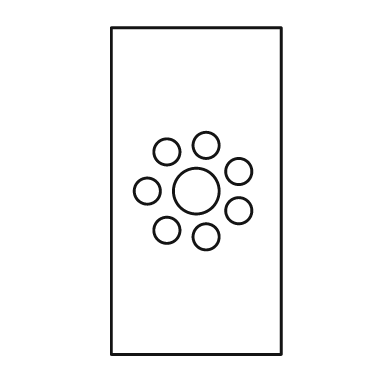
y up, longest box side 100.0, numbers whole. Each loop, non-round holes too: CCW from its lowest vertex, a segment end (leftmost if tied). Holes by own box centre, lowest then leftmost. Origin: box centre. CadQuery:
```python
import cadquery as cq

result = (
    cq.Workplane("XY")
    .moveTo(-26.0, -50.0)
    .lineTo(26.0, -50.0)
    .lineTo(26.0, 50.0)
    .lineTo(-26.0, 50.0)
    .close()
    .moveTo(3.0, -14.0)
    .circle(4.0)
    .moveTo(-9.0, -12.0)
    .circle(4.0)
    .moveTo(13.0, -6.0)
    .circle(4.0)
    .moveTo(-15.0, 0.0)
    .circle(4.0)
    .moveTo(0.0, 0.0)
    .circle(7.0)
    .moveTo(13.0, 6.0)
    .circle(4.0)
    .moveTo(-9.0, 12.0)
    .circle(4.0)
    .moveTo(3.0, 14.0)
    .circle(4.0)
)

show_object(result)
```